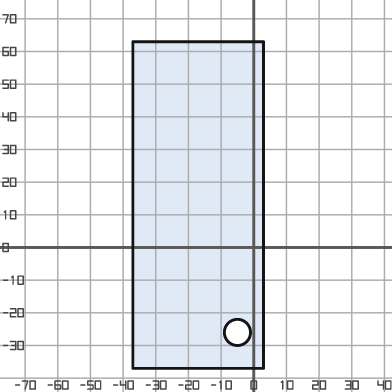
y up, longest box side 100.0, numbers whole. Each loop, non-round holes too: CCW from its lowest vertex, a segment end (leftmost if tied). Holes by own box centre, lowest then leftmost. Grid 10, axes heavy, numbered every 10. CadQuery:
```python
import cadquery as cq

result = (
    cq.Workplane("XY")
    .moveTo(-37.0, -37.0)
    .lineTo(3.0, -37.0)
    .lineTo(3.0, 63.0)
    .lineTo(-37.0, 63.0)
    .close()
    .moveTo(-5.0, -26.0)
    .circle(4.0)
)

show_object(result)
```